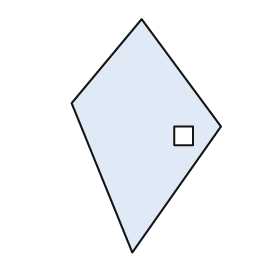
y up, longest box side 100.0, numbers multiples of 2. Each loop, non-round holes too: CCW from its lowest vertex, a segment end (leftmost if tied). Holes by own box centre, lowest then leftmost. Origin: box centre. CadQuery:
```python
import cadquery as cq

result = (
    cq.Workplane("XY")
    .moveTo(-6.0, -50.0)
    .lineTo(32.0, 4.0)
    .lineTo(-2.0, 50.0)
    .lineTo(-32.0, 14.0)
    .close()
    .moveTo(12.0, -4.0)
    .lineTo(20.0, -4.0)
    .lineTo(20.0, 4.0)
    .lineTo(12.0, 4.0)
    .close()
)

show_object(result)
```